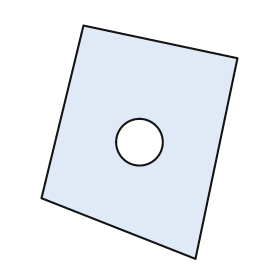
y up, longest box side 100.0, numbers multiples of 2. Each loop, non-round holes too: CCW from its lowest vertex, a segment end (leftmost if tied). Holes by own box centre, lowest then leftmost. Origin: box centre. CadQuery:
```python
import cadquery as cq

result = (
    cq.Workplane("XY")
    .moveTo(24.0, -50.0)
    .lineTo(42.0, 36.0)
    .lineTo(-24.0, 50.0)
    .lineTo(-42.0, -24.0)
    .close()
    .moveTo(0.0, 0.0)
    .circle(10.0)
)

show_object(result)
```